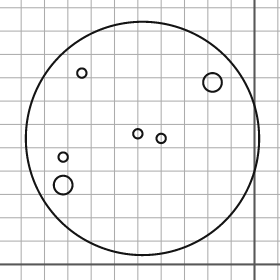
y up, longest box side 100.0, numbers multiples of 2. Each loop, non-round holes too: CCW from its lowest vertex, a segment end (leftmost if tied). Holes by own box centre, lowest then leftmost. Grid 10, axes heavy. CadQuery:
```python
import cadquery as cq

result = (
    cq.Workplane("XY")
    .moveTo(-48.0, 54.0)
    .circle(50.0)
    .moveTo(-82.0, 34.0)
    .circle(4.0)
    .moveTo(-82.0, 46.0)
    .circle(2.0)
    .moveTo(-40.0, 54.0)
    .circle(2.0)
    .moveTo(-50.0, 56.0)
    .circle(2.0)
    .moveTo(-18.0, 78.0)
    .circle(4.0)
    .moveTo(-74.0, 82.0)
    .circle(2.0)
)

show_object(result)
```